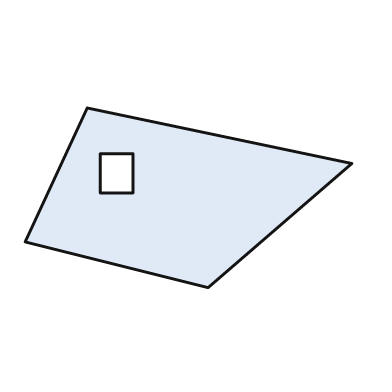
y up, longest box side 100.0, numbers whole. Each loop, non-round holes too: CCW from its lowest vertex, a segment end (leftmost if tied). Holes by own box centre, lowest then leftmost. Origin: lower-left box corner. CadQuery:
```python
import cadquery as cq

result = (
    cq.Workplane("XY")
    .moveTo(56.0, 0.0)
    .lineTo(100.0, 38.0)
    .lineTo(19.0, 55.0)
    .lineTo(0.0, 14.0)
    .close()
    .moveTo(23.0, 29.0)
    .lineTo(33.0, 29.0)
    .lineTo(33.0, 41.0)
    .lineTo(23.0, 41.0)
    .close()
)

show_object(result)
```